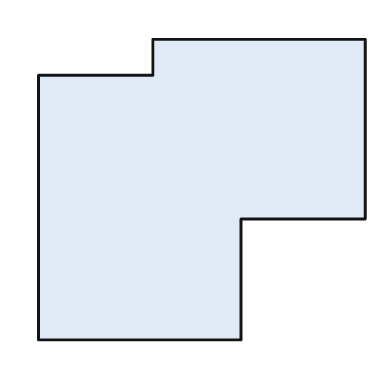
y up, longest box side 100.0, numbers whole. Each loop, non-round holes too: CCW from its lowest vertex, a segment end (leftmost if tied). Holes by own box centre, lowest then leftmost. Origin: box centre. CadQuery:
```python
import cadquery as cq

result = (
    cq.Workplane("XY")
    .moveTo(-50.0, -46.0)
    .lineTo(12.0, -46.0)
    .lineTo(12.0, -9.0)
    .lineTo(50.0, -9.0)
    .lineTo(50.0, 46.0)
    .lineTo(-15.0, 46.0)
    .lineTo(-15.0, 35.0)
    .lineTo(-50.0, 35.0)
    .close()
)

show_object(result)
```